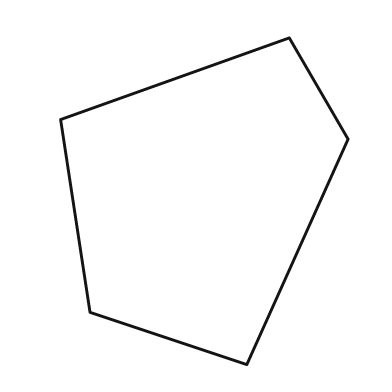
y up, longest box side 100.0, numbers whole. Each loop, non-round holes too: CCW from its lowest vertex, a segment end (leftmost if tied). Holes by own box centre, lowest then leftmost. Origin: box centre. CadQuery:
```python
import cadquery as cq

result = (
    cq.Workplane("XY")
    .moveTo(13.0, -50.0)
    .lineTo(44.0, 19.0)
    .lineTo(26.0, 50.0)
    .lineTo(-44.0, 25.0)
    .lineTo(-35.0, -34.0)
    .close()
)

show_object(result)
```